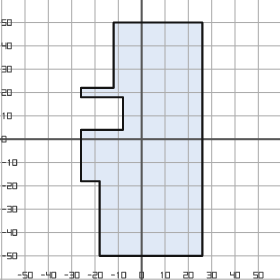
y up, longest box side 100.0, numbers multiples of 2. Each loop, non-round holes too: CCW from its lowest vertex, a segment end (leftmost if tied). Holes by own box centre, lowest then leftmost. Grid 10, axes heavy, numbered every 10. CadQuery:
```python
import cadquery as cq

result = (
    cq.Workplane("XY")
    .moveTo(-18.0, -50.0)
    .lineTo(26.0, -50.0)
    .lineTo(26.0, 50.0)
    .lineTo(-12.0, 50.0)
    .lineTo(-12.0, 22.0)
    .lineTo(-26.0, 22.0)
    .lineTo(-26.0, 18.0)
    .lineTo(-8.0, 18.0)
    .lineTo(-8.0, 4.0)
    .lineTo(-26.0, 4.0)
    .lineTo(-26.0, -18.0)
    .lineTo(-18.0, -18.0)
    .close()
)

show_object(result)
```